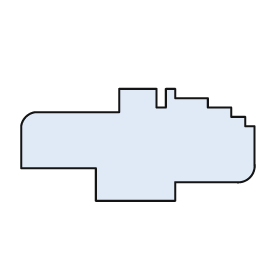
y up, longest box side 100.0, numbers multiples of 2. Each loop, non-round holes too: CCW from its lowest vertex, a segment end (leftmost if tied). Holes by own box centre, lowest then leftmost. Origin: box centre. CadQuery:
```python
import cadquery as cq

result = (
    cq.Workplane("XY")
    .moveTo(-18.0, -24.0)
    .lineTo(16.0, -24.0)
    .lineTo(16.0, -16.0)
    .lineTo(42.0, -16.0)
    .threePointArc((48.0, -14.0), (50.0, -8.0))
    .lineTo(50.0, 8.0)
    .lineTo(46.0, 8.0)
    .lineTo(46.0, 12.0)
    .lineTo(40.0, 12.0)
    .lineTo(40.0, 16.0)
    .lineTo(30.0, 16.0)
    .lineTo(30.0, 20.0)
    .lineTo(16.0, 20.0)
    .lineTo(16.0, 24.0)
    .lineTo(12.0, 24.0)
    .lineTo(12.0, 16.0)
    .lineTo(8.0, 16.0)
    .lineTo(8.0, 24.0)
    .lineTo(-8.0, 24.0)
    .lineTo(-8.0, 14.0)
    .lineTo(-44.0, 14.0)
    .threePointArc((-48.0, 12.0), (-50.0, 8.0))
    .lineTo(-50.0, -10.0)
    .lineTo(-18.0, -10.0)
    .close()
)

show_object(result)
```